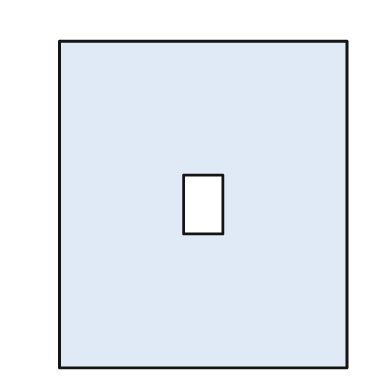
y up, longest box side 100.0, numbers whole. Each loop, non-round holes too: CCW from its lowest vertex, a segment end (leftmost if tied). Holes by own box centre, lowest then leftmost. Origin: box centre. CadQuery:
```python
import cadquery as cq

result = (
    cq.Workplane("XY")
    .moveTo(-44.0, -50.0)
    .lineTo(44.0, -50.0)
    .lineTo(44.0, 50.0)
    .lineTo(-44.0, 50.0)
    .close()
    .moveTo(-6.0, -9.0)
    .lineTo(6.0, -9.0)
    .lineTo(6.0, 9.0)
    .lineTo(-6.0, 9.0)
    .close()
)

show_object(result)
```